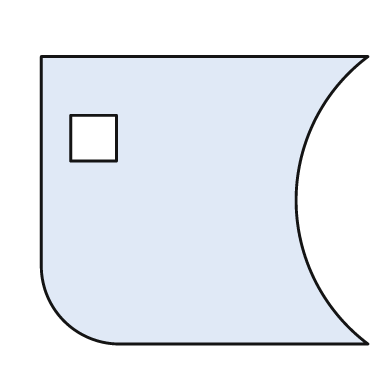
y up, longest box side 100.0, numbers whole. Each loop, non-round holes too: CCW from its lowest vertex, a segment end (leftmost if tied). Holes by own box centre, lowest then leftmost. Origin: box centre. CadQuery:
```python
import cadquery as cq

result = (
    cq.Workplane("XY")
    .moveTo(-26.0, -44.0)
    .lineTo(50.0, -44.0)
    .threePointArc((28.0, 0.0), (50.0, 44.0))
    .lineTo(-50.0, 44.0)
    .lineTo(-50.0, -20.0)
    .threePointArc((-43.0, -37.0), (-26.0, -44.0))
    .close()
    .moveTo(-41.0, 12.0)
    .lineTo(-27.0, 12.0)
    .lineTo(-27.0, 26.0)
    .lineTo(-41.0, 26.0)
    .close()
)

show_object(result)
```